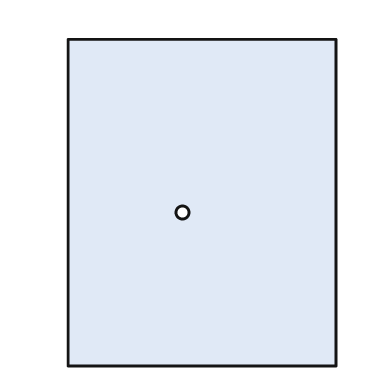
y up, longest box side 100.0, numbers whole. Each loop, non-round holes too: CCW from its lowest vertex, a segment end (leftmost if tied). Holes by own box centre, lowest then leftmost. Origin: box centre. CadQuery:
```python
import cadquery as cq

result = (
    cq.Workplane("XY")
    .moveTo(-41.0, -50.0)
    .lineTo(41.0, -50.0)
    .lineTo(41.0, 50.0)
    .lineTo(-41.0, 50.0)
    .close()
    .moveTo(-6.0, -3.0)
    .circle(2.0)
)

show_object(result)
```